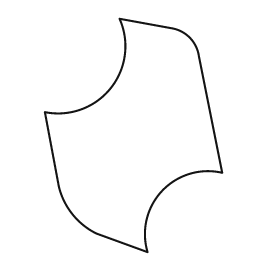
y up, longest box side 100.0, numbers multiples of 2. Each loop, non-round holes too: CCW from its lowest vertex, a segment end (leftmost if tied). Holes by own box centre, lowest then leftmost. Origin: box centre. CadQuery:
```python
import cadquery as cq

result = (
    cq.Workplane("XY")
    .moveTo(6.0, -50.0)
    .threePointArc((12.0, -24.0), (38.0, -16.0))
    .lineTo(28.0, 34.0)
    .threePointArc((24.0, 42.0), (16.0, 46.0))
    .lineTo(-6.0, 50.0)
    .threePointArc((-10.0, 20.0), (-38.0, 10.0))
    .lineTo(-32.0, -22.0)
    .threePointArc((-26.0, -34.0), (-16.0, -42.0))
    .close()
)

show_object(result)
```